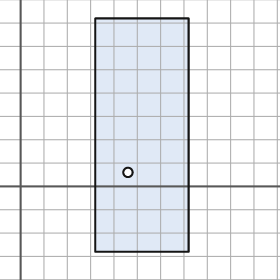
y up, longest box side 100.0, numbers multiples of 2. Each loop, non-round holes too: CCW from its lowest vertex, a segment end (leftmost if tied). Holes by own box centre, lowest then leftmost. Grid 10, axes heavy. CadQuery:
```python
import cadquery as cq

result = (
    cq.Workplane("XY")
    .moveTo(32.0, -28.0)
    .lineTo(72.0, -28.0)
    .lineTo(72.0, 72.0)
    .lineTo(32.0, 72.0)
    .close()
    .moveTo(46.0, 6.0)
    .circle(2.0)
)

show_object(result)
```